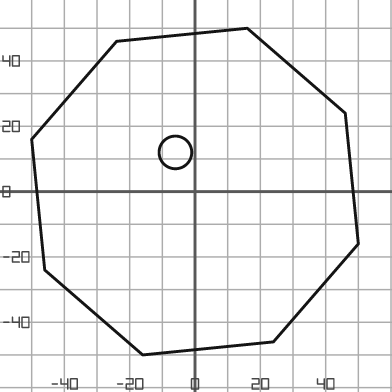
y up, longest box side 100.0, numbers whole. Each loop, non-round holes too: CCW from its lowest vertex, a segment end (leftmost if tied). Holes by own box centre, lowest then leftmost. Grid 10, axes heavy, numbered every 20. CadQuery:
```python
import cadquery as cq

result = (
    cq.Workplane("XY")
    .moveTo(-16.0, -50.0)
    .lineTo(24.0, -46.0)
    .lineTo(50.0, -16.0)
    .lineTo(46.0, 24.0)
    .lineTo(16.0, 50.0)
    .lineTo(-24.0, 46.0)
    .lineTo(-50.0, 16.0)
    .lineTo(-46.0, -24.0)
    .close()
    .moveTo(-6.0, 12.0)
    .circle(5.0)
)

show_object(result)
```